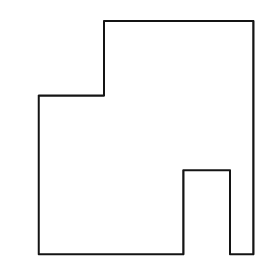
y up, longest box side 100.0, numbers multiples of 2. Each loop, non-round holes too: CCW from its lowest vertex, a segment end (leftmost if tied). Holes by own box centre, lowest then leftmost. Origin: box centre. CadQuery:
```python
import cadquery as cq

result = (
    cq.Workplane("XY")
    .moveTo(-46.0, -50.0)
    .lineTo(16.0, -50.0)
    .lineTo(16.0, -14.0)
    .lineTo(36.0, -14.0)
    .lineTo(36.0, -50.0)
    .lineTo(46.0, -50.0)
    .lineTo(46.0, 50.0)
    .lineTo(-18.0, 50.0)
    .lineTo(-18.0, 18.0)
    .lineTo(-46.0, 18.0)
    .close()
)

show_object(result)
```